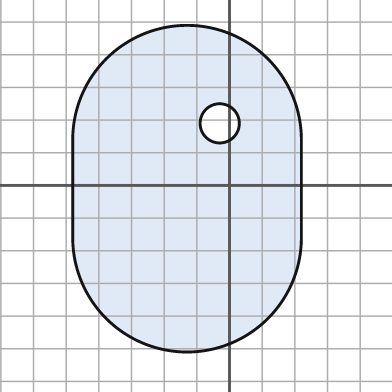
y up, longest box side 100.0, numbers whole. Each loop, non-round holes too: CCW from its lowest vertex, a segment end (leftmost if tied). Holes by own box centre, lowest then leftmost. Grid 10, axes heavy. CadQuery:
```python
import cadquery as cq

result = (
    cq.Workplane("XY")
    .moveTo(-48.0, -16.0)
    .threePointArc((-13.0, -51.0), (22.0, -16.0))
    .lineTo(22.0, 14.0)
    .threePointArc((-13.0, 49.0), (-48.0, 14.0))
    .close()
    .moveTo(-3.0, 19.0)
    .circle(6.0)
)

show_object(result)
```